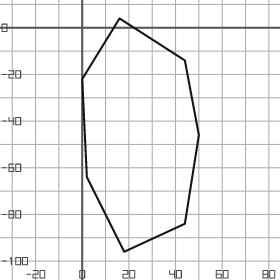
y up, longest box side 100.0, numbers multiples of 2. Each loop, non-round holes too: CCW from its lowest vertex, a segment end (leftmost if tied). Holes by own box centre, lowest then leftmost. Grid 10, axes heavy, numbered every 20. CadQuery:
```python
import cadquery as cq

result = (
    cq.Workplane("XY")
    .moveTo(18.0, -96.0)
    .lineTo(44.0, -84.0)
    .lineTo(50.0, -46.0)
    .lineTo(44.0, -14.0)
    .lineTo(16.0, 4.0)
    .lineTo(0.0, -22.0)
    .lineTo(2.0, -64.0)
    .close()
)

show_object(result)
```